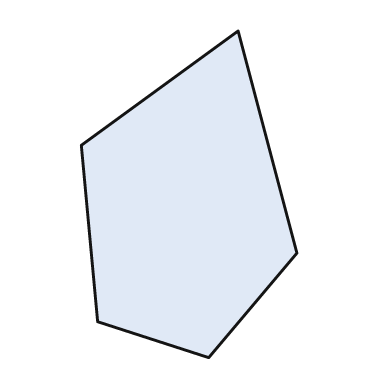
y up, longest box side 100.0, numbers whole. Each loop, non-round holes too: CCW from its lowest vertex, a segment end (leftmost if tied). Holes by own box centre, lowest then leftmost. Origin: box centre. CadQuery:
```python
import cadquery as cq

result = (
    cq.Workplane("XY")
    .moveTo(6.0, -50.0)
    .lineTo(33.0, -18.0)
    .lineTo(15.0, 50.0)
    .lineTo(-33.0, 15.0)
    .lineTo(-28.0, -39.0)
    .close()
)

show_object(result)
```